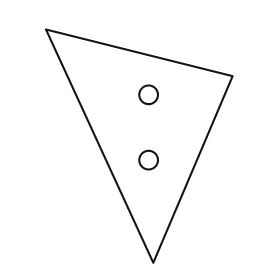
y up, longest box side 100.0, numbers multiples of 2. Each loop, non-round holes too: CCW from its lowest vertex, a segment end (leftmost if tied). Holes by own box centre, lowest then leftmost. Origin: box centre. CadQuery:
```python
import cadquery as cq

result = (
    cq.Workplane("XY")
    .moveTo(6.0, -50.0)
    .lineTo(40.0, 30.0)
    .lineTo(-40.0, 50.0)
    .close()
    .moveTo(4.0, -6.0)
    .circle(4.0)
    .moveTo(4.0, 22.0)
    .circle(4.0)
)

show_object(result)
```